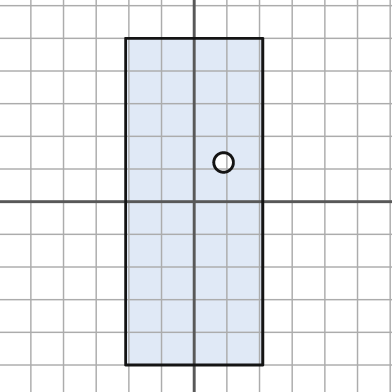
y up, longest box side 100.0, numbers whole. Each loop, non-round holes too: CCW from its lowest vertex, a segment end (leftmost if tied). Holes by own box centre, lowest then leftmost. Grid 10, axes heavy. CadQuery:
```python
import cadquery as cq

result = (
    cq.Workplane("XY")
    .moveTo(-21.0, -50.0)
    .lineTo(21.0, -50.0)
    .lineTo(21.0, 50.0)
    .lineTo(-21.0, 50.0)
    .close()
    .moveTo(9.0, 12.0)
    .circle(3.0)
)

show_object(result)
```